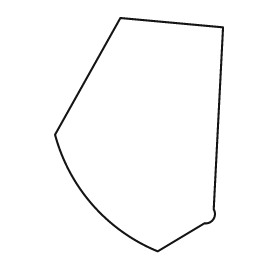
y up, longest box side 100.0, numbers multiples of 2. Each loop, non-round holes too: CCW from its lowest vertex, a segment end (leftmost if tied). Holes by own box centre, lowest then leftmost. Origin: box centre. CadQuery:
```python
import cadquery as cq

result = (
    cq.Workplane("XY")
    .moveTo(8.0, -50.0)
    .lineTo(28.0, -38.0)
    .threePointArc((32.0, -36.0), (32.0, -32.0))
    .lineTo(36.0, 46.0)
    .lineTo(-8.0, 50.0)
    .lineTo(-36.0, 0.0)
    .threePointArc((-20.0, -30.0), (8.0, -50.0))
    .close()
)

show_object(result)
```